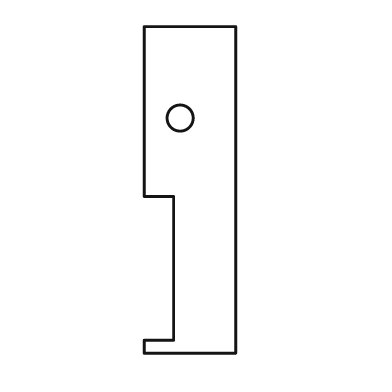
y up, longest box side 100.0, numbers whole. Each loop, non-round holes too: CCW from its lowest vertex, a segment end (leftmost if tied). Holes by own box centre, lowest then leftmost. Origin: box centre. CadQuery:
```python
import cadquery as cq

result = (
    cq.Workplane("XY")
    .moveTo(-14.0, -50.0)
    .lineTo(14.0, -50.0)
    .lineTo(14.0, 50.0)
    .lineTo(-14.0, 50.0)
    .lineTo(-14.0, -2.0)
    .lineTo(-5.0, -2.0)
    .lineTo(-5.0, -46.0)
    .lineTo(-14.0, -46.0)
    .close()
    .moveTo(-3.0, 22.0)
    .circle(4.0)
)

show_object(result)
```